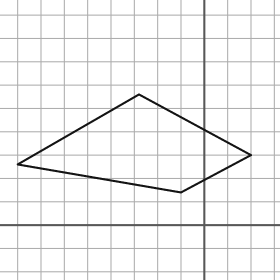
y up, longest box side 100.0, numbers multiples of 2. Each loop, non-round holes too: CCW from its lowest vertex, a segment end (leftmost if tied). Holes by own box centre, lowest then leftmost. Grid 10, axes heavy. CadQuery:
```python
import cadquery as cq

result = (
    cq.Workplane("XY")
    .moveTo(-10.0, 14.0)
    .lineTo(20.0, 30.0)
    .lineTo(-28.0, 56.0)
    .lineTo(-80.0, 26.0)
    .close()
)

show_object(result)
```